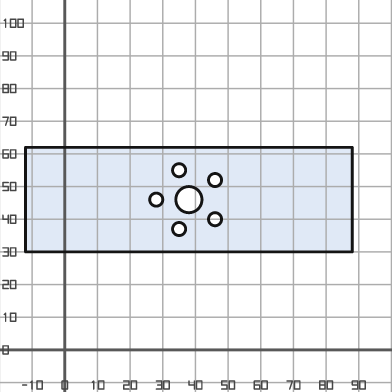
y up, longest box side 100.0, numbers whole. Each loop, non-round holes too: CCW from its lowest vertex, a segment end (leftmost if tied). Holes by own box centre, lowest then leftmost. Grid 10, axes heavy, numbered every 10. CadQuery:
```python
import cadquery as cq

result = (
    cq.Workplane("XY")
    .moveTo(-12.0, 30.0)
    .lineTo(88.0, 30.0)
    .lineTo(88.0, 62.0)
    .lineTo(-12.0, 62.0)
    .close()
    .moveTo(35.0, 37.0)
    .circle(2.0)
    .moveTo(46.0, 40.0)
    .circle(2.0)
    .moveTo(28.0, 46.0)
    .circle(2.0)
    .moveTo(38.0, 46.0)
    .circle(4.0)
    .moveTo(46.0, 52.0)
    .circle(2.0)
    .moveTo(35.0, 55.0)
    .circle(2.0)
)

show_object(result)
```